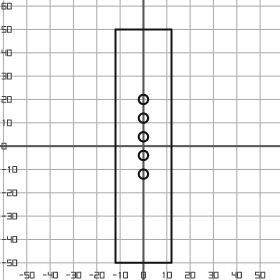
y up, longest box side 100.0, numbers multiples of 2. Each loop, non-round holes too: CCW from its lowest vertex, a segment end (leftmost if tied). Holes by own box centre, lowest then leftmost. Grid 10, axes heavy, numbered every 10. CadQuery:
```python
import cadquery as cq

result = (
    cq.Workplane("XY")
    .moveTo(-12.0, -50.0)
    .lineTo(12.0, -50.0)
    .lineTo(12.0, 50.0)
    .lineTo(-12.0, 50.0)
    .close()
    .moveTo(0.0, -12.0)
    .circle(2.0)
    .moveTo(0.0, -4.0)
    .circle(2.0)
    .moveTo(0.0, 4.0)
    .circle(2.0)
    .moveTo(0.0, 12.0)
    .circle(2.0)
    .moveTo(0.0, 20.0)
    .circle(2.0)
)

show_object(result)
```